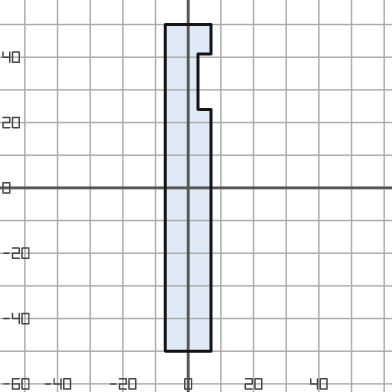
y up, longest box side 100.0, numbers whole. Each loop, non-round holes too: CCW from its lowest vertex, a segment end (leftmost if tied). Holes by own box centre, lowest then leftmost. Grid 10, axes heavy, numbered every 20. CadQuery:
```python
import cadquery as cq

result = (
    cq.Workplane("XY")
    .moveTo(-7.0, -50.0)
    .lineTo(7.0, -50.0)
    .lineTo(7.0, 24.0)
    .lineTo(3.0, 24.0)
    .lineTo(3.0, 41.0)
    .lineTo(7.0, 41.0)
    .lineTo(7.0, 50.0)
    .lineTo(-7.0, 50.0)
    .close()
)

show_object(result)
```